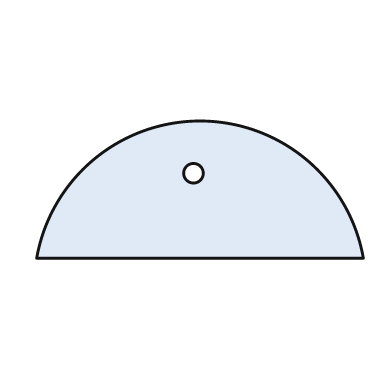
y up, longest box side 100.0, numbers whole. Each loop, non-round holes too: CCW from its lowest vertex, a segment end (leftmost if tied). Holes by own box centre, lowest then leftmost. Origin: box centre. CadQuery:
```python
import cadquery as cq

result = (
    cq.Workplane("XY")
    .moveTo(-50.0, -21.0)
    .lineTo(50.0, -21.0)
    .threePointArc((0.0, 21.0), (-50.0, -21.0))
    .close()
    .moveTo(-2.0, 5.0)
    .circle(3.0)
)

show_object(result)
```